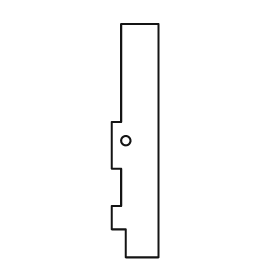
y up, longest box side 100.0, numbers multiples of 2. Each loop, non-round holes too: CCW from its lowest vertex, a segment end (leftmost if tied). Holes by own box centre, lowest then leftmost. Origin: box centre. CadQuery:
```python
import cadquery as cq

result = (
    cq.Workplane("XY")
    .moveTo(-4.0, -50.0)
    .lineTo(10.0, -50.0)
    .lineTo(10.0, 50.0)
    .lineTo(-6.0, 50.0)
    .lineTo(-6.0, 8.0)
    .lineTo(-10.0, 8.0)
    .lineTo(-10.0, -12.0)
    .lineTo(-6.0, -12.0)
    .lineTo(-6.0, -28.0)
    .lineTo(-10.0, -28.0)
    .lineTo(-10.0, -38.0)
    .lineTo(-4.0, -38.0)
    .close()
    .moveTo(-4.0, 0.0)
    .circle(2.0)
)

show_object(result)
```